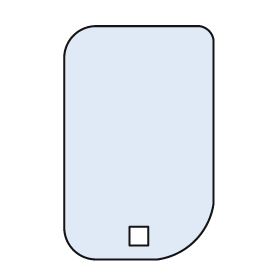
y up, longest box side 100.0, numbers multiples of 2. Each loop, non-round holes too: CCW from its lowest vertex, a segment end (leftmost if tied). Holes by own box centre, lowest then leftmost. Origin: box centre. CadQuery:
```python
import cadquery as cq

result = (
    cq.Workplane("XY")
    .moveTo(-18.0, -50.0)
    .lineTo(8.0, -50.0)
    .threePointArc((24.0, -42.0), (32.0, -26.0))
    .lineTo(32.0, 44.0)
    .threePointArc((30.0, 48.0), (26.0, 50.0))
    .lineTo(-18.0, 50.0)
    .threePointArc((-28.0, 46.0), (-32.0, 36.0))
    .lineTo(-32.0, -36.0)
    .threePointArc((-28.0, -46.0), (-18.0, -50.0))
    .close()
    .moveTo(-4.0, -44.0)
    .lineTo(4.0, -44.0)
    .lineTo(4.0, -36.0)
    .lineTo(-4.0, -36.0)
    .close()
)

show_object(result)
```